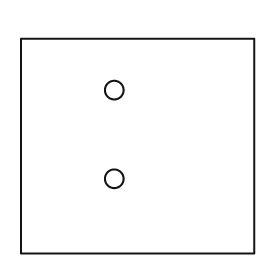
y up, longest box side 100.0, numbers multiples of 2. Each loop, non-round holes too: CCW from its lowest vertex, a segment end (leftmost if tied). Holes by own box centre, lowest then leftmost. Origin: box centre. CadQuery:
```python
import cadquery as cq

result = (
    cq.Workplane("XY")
    .moveTo(-50.0, -46.0)
    .lineTo(50.0, -46.0)
    .lineTo(50.0, 46.0)
    .lineTo(-50.0, 46.0)
    .close()
    .moveTo(-10.0, -14.0)
    .circle(4.0)
    .moveTo(-10.0, 24.0)
    .circle(4.0)
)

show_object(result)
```